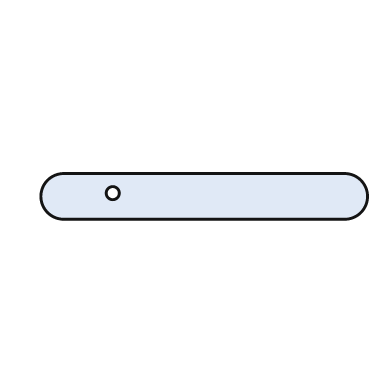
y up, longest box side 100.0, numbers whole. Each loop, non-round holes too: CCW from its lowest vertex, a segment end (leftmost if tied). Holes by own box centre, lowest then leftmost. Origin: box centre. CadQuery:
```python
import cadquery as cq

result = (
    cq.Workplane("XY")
    .moveTo(-43.0, -7.0)
    .lineTo(43.0, -7.0)
    .threePointArc((50.0, 0.0), (43.0, 7.0))
    .lineTo(-43.0, 7.0)
    .threePointArc((-50.0, 0.0), (-43.0, -7.0))
    .close()
    .moveTo(-28.0, 1.0)
    .circle(2.0)
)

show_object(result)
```